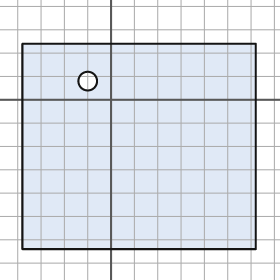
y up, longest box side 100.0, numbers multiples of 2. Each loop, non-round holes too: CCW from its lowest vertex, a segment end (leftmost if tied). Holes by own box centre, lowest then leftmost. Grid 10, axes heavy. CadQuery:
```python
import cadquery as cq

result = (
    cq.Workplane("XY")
    .moveTo(-38.0, -64.0)
    .lineTo(62.0, -64.0)
    .lineTo(62.0, 24.0)
    .lineTo(-38.0, 24.0)
    .close()
    .moveTo(-10.0, 8.0)
    .circle(4.0)
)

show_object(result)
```